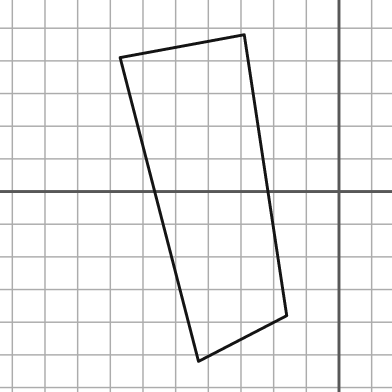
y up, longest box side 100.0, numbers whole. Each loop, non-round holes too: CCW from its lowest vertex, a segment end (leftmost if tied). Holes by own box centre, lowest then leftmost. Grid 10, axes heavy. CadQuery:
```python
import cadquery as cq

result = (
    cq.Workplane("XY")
    .moveTo(-43.0, -52.0)
    .lineTo(-16.0, -38.0)
    .lineTo(-29.0, 48.0)
    .lineTo(-67.0, 41.0)
    .close()
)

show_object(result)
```